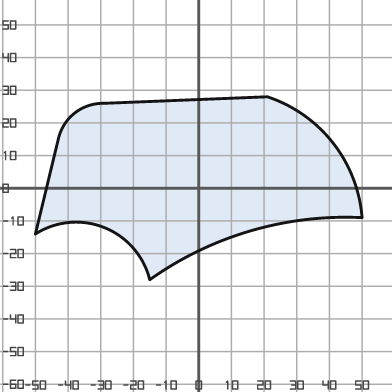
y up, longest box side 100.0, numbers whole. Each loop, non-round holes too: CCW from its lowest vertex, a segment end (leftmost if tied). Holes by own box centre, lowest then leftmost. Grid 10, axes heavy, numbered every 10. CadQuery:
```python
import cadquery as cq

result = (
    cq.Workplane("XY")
    .moveTo(-15.0, -28.0)
    .threePointArc((16.0, -13.0), (50.0, -9.0))
    .threePointArc((41.0, 14.0), (21.0, 28.0))
    .lineTo(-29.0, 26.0)
    .threePointArc((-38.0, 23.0), (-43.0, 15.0))
    .lineTo(-50.0, -14.0)
    .threePointArc((-29.0, -12.0), (-15.0, -28.0))
    .close()
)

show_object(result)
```